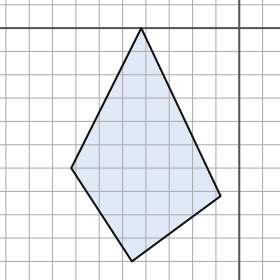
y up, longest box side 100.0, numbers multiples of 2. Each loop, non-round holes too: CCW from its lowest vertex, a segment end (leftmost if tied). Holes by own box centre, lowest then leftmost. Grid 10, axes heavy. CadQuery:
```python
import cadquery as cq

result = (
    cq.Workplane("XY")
    .moveTo(-46.0, -100.0)
    .lineTo(-8.0, -72.0)
    .lineTo(-42.0, 0.0)
    .lineTo(-72.0, -60.0)
    .close()
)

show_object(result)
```